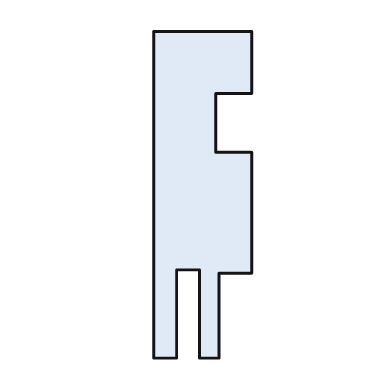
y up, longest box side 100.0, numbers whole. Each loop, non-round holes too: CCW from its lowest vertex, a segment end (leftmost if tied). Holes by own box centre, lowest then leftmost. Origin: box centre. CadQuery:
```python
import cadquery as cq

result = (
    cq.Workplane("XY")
    .moveTo(-15.0, -50.0)
    .lineTo(-8.0, -50.0)
    .lineTo(-8.0, -23.0)
    .lineTo(-1.0, -23.0)
    .lineTo(-1.0, -50.0)
    .lineTo(5.0, -50.0)
    .lineTo(5.0, -24.0)
    .lineTo(15.0, -24.0)
    .lineTo(15.0, 13.0)
    .lineTo(4.0, 13.0)
    .lineTo(4.0, 31.0)
    .lineTo(15.0, 31.0)
    .lineTo(15.0, 50.0)
    .lineTo(-15.0, 50.0)
    .close()
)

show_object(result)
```